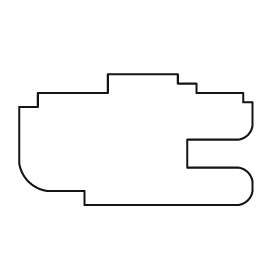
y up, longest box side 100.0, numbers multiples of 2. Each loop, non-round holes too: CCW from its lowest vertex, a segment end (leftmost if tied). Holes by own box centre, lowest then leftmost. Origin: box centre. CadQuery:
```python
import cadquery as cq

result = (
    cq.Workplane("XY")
    .moveTo(-22.0, -28.0)
    .lineTo(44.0, -28.0)
    .threePointArc((48.0, -26.0), (50.0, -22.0))
    .lineTo(50.0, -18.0)
    .threePointArc((48.0, -14.0), (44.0, -12.0))
    .lineTo(22.0, -12.0)
    .lineTo(22.0, 0.0)
    .lineTo(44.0, 0.0)
    .threePointArc((48.0, 2.0), (50.0, 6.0))
    .lineTo(50.0, 16.0)
    .lineTo(46.0, 16.0)
    .lineTo(46.0, 20.0)
    .lineTo(26.0, 20.0)
    .lineTo(26.0, 24.0)
    .lineTo(18.0, 24.0)
    .lineTo(18.0, 28.0)
    .lineTo(-12.0, 28.0)
    .lineTo(-12.0, 20.0)
    .lineTo(-42.0, 20.0)
    .lineTo(-42.0, 14.0)
    .lineTo(-50.0, 14.0)
    .lineTo(-50.0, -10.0)
    .threePointArc((-46.0, -18.0), (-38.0, -22.0))
    .lineTo(-22.0, -22.0)
    .close()
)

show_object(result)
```